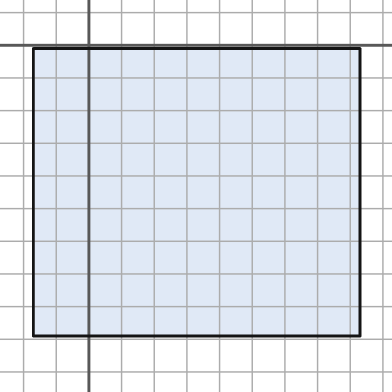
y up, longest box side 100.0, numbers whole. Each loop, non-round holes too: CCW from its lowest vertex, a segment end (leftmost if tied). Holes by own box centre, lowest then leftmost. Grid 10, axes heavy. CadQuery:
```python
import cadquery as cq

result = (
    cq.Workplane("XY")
    .moveTo(-17.0, -89.0)
    .lineTo(83.0, -89.0)
    .lineTo(83.0, -1.0)
    .lineTo(-17.0, -1.0)
    .close()
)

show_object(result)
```